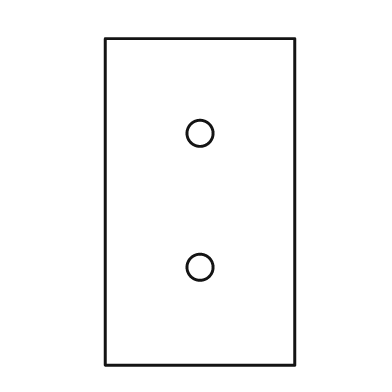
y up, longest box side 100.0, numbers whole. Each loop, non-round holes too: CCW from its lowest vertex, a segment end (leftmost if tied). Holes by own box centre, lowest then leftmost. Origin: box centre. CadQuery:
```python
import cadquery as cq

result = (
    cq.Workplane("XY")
    .moveTo(-29.0, -50.0)
    .lineTo(29.0, -50.0)
    .lineTo(29.0, 50.0)
    .lineTo(-29.0, 50.0)
    .close()
    .moveTo(0.0, -20.0)
    .circle(4.0)
    .moveTo(0.0, 21.0)
    .circle(4.0)
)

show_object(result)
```